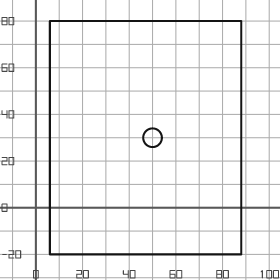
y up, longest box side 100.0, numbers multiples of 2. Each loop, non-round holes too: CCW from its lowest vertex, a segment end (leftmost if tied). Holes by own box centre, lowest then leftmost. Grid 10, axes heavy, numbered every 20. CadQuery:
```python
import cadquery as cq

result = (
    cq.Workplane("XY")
    .moveTo(6.0, -20.0)
    .lineTo(88.0, -20.0)
    .lineTo(88.0, 80.0)
    .lineTo(6.0, 80.0)
    .close()
    .moveTo(50.0, 30.0)
    .circle(4.0)
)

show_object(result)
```